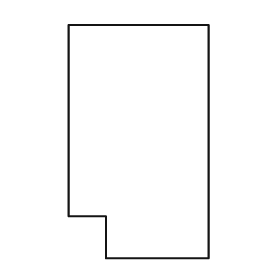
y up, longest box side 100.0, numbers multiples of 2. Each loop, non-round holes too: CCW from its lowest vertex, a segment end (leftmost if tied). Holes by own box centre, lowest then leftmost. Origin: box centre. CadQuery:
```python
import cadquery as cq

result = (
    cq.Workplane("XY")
    .moveTo(-14.0, -50.0)
    .lineTo(30.0, -50.0)
    .lineTo(30.0, 50.0)
    .lineTo(-30.0, 50.0)
    .lineTo(-30.0, -32.0)
    .lineTo(-14.0, -32.0)
    .close()
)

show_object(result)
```